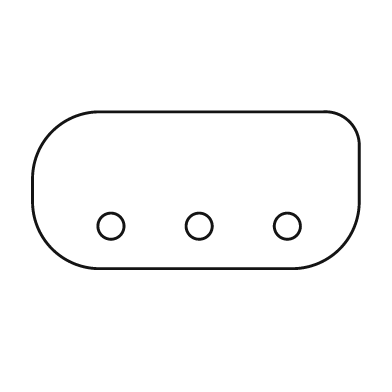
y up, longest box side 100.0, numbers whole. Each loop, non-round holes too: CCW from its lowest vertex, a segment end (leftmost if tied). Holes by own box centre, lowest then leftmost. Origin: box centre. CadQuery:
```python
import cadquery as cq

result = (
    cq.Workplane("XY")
    .moveTo(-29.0, -24.0)
    .lineTo(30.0, -24.0)
    .threePointArc((44.0, -18.0), (50.0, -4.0))
    .lineTo(50.0, 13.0)
    .threePointArc((47.0, 21.0), (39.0, 24.0))
    .lineTo(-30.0, 24.0)
    .threePointArc((-44.0, 18.0), (-50.0, 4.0))
    .lineTo(-50.0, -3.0)
    .threePointArc((-44.0, -18.0), (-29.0, -24.0))
    .close()
    .moveTo(-26.0, -11.0)
    .circle(4.0)
    .moveTo(1.0, -11.0)
    .circle(4.0)
    .moveTo(28.0, -11.0)
    .circle(4.0)
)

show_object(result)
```